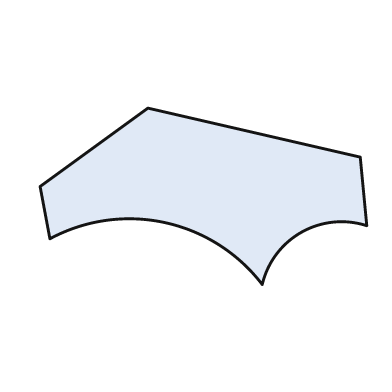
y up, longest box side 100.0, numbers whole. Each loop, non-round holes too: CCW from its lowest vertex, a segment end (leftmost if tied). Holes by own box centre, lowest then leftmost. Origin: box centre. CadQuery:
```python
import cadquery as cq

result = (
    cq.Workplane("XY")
    .moveTo(18.0, -27.0)
    .threePointArc((30.0, -11.0), (50.0, -9.0))
    .lineTo(48.0, 12.0)
    .lineTo(-17.0, 27.0)
    .lineTo(-50.0, 3.0)
    .lineTo(-47.0, -13.0)
    .threePointArc((-12.0, -8.0), (18.0, -27.0))
    .close()
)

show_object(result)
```